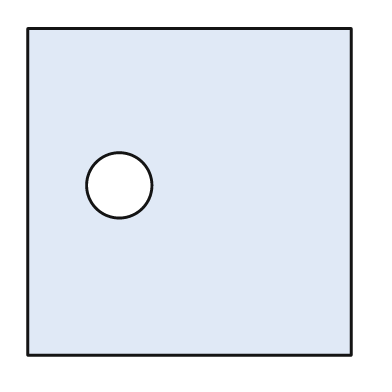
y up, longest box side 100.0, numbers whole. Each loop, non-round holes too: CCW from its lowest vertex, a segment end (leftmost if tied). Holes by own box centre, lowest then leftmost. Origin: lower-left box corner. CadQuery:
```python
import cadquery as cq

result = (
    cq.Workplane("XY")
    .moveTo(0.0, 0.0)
    .lineTo(99.0, 0.0)
    .lineTo(99.0, 100.0)
    .lineTo(0.0, 100.0)
    .close()
    .moveTo(28.0, 52.0)
    .circle(10.0)
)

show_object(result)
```